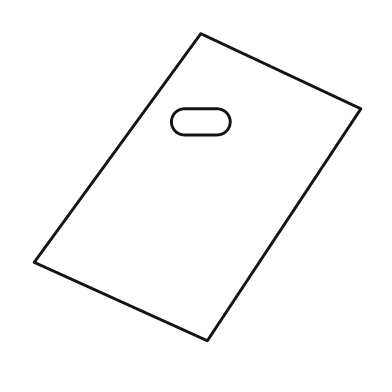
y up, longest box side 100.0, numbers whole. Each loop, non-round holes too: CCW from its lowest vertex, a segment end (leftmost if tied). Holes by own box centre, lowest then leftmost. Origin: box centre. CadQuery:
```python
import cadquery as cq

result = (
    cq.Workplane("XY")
    .moveTo(3.0, -47.0)
    .lineTo(50.0, 24.0)
    .lineTo(1.0, 47.0)
    .lineTo(-50.0, -23.0)
    .close()
    .moveTo(-4.0, 16.0)
    .lineTo(6.0, 16.0)
    .threePointArc((10.0, 20.0), (6.0, 24.0))
    .lineTo(-4.0, 24.0)
    .threePointArc((-8.0, 20.0), (-4.0, 16.0))
    .close()
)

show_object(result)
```